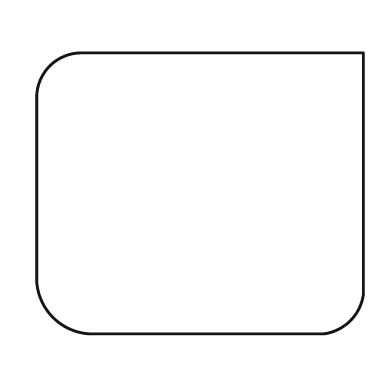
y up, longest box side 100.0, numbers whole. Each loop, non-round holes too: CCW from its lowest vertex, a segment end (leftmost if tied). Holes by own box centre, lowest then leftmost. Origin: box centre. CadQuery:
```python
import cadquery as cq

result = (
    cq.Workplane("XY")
    .moveTo(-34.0, -43.0)
    .lineTo(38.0, -43.0)
    .threePointArc((46.0, -39.0), (50.0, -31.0))
    .lineTo(50.0, 43.0)
    .lineTo(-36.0, 43.0)
    .threePointArc((-46.0, 39.0), (-50.0, 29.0))
    .lineTo(-50.0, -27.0)
    .threePointArc((-45.0, -38.0), (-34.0, -43.0))
    .close()
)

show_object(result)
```